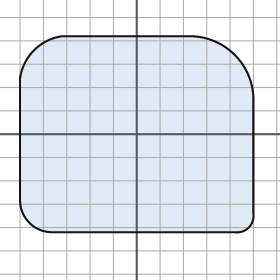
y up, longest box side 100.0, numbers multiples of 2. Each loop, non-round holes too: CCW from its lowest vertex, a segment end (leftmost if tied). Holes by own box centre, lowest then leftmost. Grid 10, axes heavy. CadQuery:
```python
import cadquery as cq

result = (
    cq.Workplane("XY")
    .moveTo(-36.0, -42.0)
    .lineTo(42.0, -42.0)
    .threePointArc((48.0, -40.0), (50.0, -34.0))
    .lineTo(50.0, 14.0)
    .threePointArc((42.0, 34.0), (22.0, 42.0))
    .lineTo(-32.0, 42.0)
    .threePointArc((-44.0, 36.0), (-50.0, 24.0))
    .lineTo(-50.0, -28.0)
    .threePointArc((-46.0, -38.0), (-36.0, -42.0))
    .close()
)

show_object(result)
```